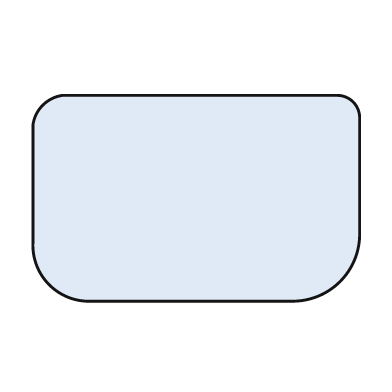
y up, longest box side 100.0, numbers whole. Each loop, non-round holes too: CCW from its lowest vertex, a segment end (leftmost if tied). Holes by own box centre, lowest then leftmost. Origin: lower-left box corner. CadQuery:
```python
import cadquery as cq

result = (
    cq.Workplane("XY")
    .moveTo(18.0, 0.0)
    .lineTo(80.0, 0.0)
    .threePointArc((94.0, 6.0), (100.0, 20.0))
    .lineTo(100.0, 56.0)
    .threePointArc((98.0, 61.0), (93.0, 63.0))
    .lineTo(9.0, 63.0)
    .threePointArc((3.0, 60.0), (0.0, 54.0))
    .lineTo(0.0, 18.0)
    .threePointArc((5.0, 5.0), (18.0, 0.0))
    .close()
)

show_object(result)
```